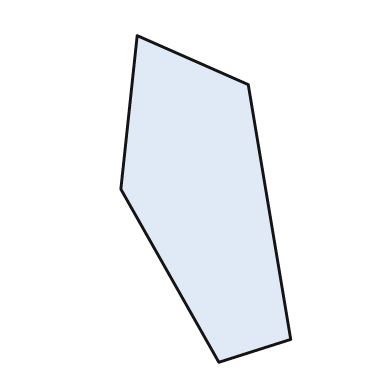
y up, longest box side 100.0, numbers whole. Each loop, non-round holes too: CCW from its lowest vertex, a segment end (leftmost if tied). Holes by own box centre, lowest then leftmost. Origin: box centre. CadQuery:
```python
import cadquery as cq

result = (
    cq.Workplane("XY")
    .moveTo(4.0, -50.0)
    .lineTo(26.0, -43.0)
    .lineTo(13.0, 35.0)
    .lineTo(-21.0, 50.0)
    .lineTo(-26.0, 3.0)
    .close()
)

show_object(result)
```